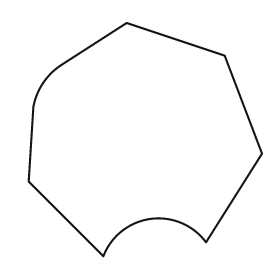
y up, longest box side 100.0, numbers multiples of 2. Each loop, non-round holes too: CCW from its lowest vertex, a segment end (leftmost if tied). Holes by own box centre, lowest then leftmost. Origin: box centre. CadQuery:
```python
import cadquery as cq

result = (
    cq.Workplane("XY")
    .moveTo(-18.0, -50.0)
    .threePointArc((2.0, -34.0), (26.0, -44.0))
    .lineTo(50.0, -6.0)
    .lineTo(34.0, 36.0)
    .lineTo(-8.0, 50.0)
    .lineTo(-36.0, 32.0)
    .threePointArc((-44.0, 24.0), (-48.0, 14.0))
    .lineTo(-50.0, -18.0)
    .close()
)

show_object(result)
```